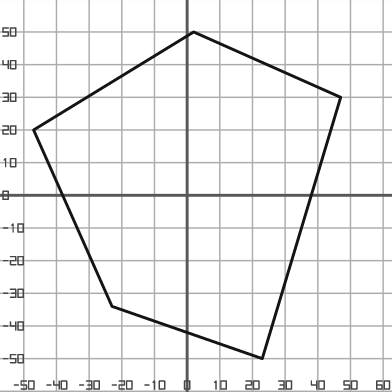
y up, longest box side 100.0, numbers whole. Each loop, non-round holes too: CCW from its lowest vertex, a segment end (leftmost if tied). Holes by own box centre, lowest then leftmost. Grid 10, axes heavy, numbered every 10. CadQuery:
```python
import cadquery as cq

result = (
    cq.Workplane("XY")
    .moveTo(23.0, -50.0)
    .lineTo(47.0, 30.0)
    .lineTo(2.0, 50.0)
    .lineTo(-47.0, 20.0)
    .lineTo(-23.0, -34.0)
    .close()
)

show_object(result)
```